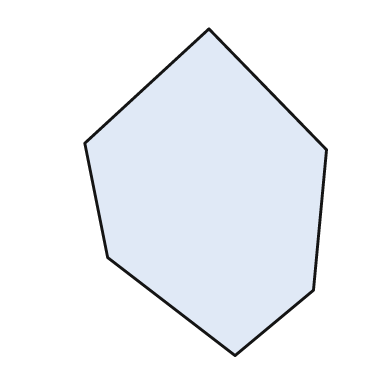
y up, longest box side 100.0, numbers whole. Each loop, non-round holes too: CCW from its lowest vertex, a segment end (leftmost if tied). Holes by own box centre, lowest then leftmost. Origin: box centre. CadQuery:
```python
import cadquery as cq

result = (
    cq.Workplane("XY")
    .moveTo(9.0, -50.0)
    .lineTo(33.0, -30.0)
    .lineTo(37.0, 13.0)
    .lineTo(1.0, 50.0)
    .lineTo(-37.0, 15.0)
    .lineTo(-30.0, -20.0)
    .close()
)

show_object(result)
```